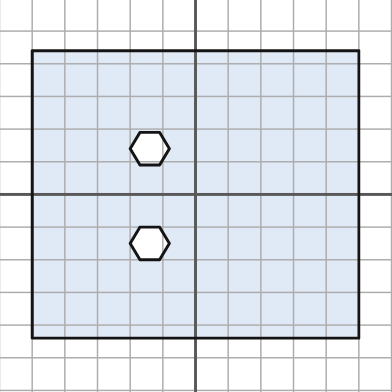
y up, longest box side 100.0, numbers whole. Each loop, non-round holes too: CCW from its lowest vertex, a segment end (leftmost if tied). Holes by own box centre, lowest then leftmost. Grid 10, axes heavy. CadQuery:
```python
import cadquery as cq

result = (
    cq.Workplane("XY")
    .moveTo(-50.0, -44.0)
    .lineTo(50.0, -44.0)
    .lineTo(50.0, 44.0)
    .lineTo(-50.0, 44.0)
    .close()
    .moveTo(-17.0, -20.0)
    .lineTo(-11.0, -20.0)
    .lineTo(-8.0, -15.0)
    .lineTo(-11.0, -10.0)
    .lineTo(-17.0, -10.0)
    .lineTo(-20.0, -15.0)
    .close()
    .moveTo(-17.0, 9.0)
    .lineTo(-11.0, 9.0)
    .lineTo(-8.0, 14.0)
    .lineTo(-11.0, 19.0)
    .lineTo(-17.0, 19.0)
    .lineTo(-20.0, 14.0)
    .close()
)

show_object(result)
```